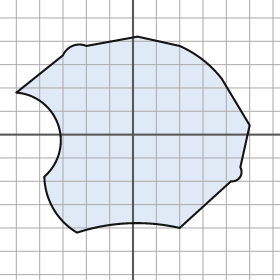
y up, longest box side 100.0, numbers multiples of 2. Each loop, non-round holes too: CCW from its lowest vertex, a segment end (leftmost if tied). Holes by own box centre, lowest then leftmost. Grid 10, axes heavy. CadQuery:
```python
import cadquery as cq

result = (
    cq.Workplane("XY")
    .moveTo(-24.0, -42.0)
    .threePointArc((-2.0, -38.0), (20.0, -40.0))
    .lineTo(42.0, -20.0)
    .threePointArc((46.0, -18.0), (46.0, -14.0))
    .lineTo(50.0, 4.0)
    .lineTo(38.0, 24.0)
    .threePointArc((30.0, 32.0), (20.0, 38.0))
    .lineTo(2.0, 42.0)
    .lineTo(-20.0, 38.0)
    .threePointArc((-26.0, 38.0), (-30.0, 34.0))
    .lineTo(-50.0, 18.0)
    .threePointArc((-32.0, 4.0), (-38.0, -18.0))
    .threePointArc((-34.0, -32.0), (-24.0, -42.0))
    .close()
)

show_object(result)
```